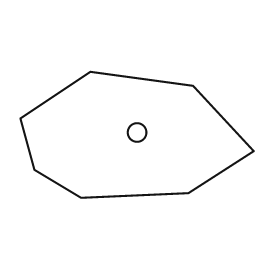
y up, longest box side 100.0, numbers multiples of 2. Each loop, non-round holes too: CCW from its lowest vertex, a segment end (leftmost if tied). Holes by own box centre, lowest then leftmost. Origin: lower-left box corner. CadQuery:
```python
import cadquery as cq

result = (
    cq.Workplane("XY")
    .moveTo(26.0, 0.0)
    .lineTo(72.0, 2.0)
    .lineTo(100.0, 20.0)
    .lineTo(74.0, 48.0)
    .lineTo(30.0, 54.0)
    .lineTo(0.0, 34.0)
    .lineTo(6.0, 12.0)
    .close()
    .moveTo(50.0, 28.0)
    .circle(4.0)
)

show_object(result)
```